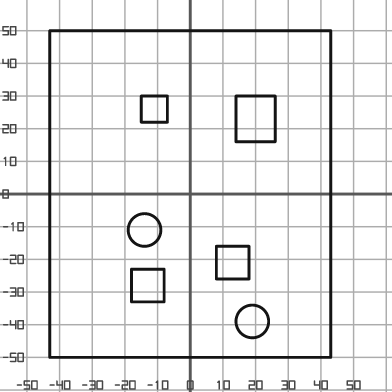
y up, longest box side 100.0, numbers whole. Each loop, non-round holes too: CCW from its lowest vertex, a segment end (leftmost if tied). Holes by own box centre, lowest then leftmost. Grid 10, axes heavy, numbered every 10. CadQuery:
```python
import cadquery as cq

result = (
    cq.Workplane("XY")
    .moveTo(-43.0, -50.0)
    .lineTo(43.0, -50.0)
    .lineTo(43.0, 50.0)
    .lineTo(-43.0, 50.0)
    .close()
    .moveTo(19.0, -39.0)
    .circle(5.0)
    .moveTo(-18.0, -33.0)
    .lineTo(-8.0, -33.0)
    .lineTo(-8.0, -23.0)
    .lineTo(-18.0, -23.0)
    .close()
    .moveTo(8.0, -26.0)
    .lineTo(18.0, -26.0)
    .lineTo(18.0, -16.0)
    .lineTo(8.0, -16.0)
    .close()
    .moveTo(-14.0, -11.0)
    .circle(5.0)
    .moveTo(14.0, 16.0)
    .lineTo(26.0, 16.0)
    .lineTo(26.0, 30.0)
    .lineTo(14.0, 30.0)
    .close()
    .moveTo(-15.0, 22.0)
    .lineTo(-7.0, 22.0)
    .lineTo(-7.0, 30.0)
    .lineTo(-15.0, 30.0)
    .close()
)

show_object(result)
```